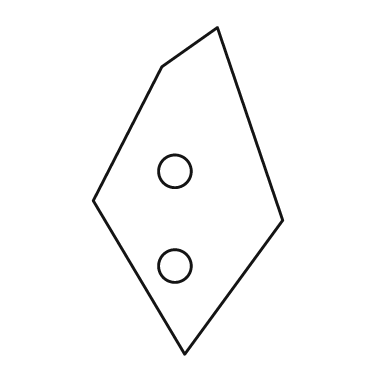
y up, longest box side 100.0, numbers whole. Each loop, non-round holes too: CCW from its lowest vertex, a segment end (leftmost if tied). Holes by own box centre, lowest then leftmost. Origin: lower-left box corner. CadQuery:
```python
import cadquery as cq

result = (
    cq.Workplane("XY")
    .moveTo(28.0, 0.0)
    .lineTo(58.0, 41.0)
    .lineTo(38.0, 100.0)
    .lineTo(21.0, 88.0)
    .lineTo(0.0, 47.0)
    .close()
    .moveTo(25.0, 27.0)
    .circle(5.0)
    .moveTo(25.0, 56.0)
    .circle(5.0)
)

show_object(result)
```